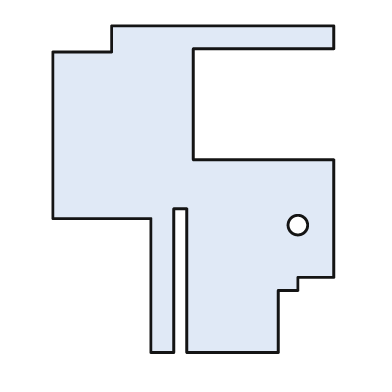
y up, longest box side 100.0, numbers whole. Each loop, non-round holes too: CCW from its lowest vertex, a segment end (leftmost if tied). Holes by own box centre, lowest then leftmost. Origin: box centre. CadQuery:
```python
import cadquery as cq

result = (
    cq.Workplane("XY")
    .moveTo(-13.0, -50.0)
    .lineTo(-6.0, -50.0)
    .lineTo(-6.0, -6.0)
    .lineTo(-2.0, -6.0)
    .lineTo(-2.0, -50.0)
    .lineTo(26.0, -50.0)
    .lineTo(26.0, -31.0)
    .lineTo(32.0, -31.0)
    .lineTo(32.0, -27.0)
    .lineTo(43.0, -27.0)
    .lineTo(43.0, 9.0)
    .lineTo(0.0, 9.0)
    .lineTo(0.0, 43.0)
    .lineTo(43.0, 43.0)
    .lineTo(43.0, 50.0)
    .lineTo(-25.0, 50.0)
    .lineTo(-25.0, 42.0)
    .lineTo(-43.0, 42.0)
    .lineTo(-43.0, -9.0)
    .lineTo(-13.0, -9.0)
    .close()
    .moveTo(32.0, -11.0)
    .circle(3.0)
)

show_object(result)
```